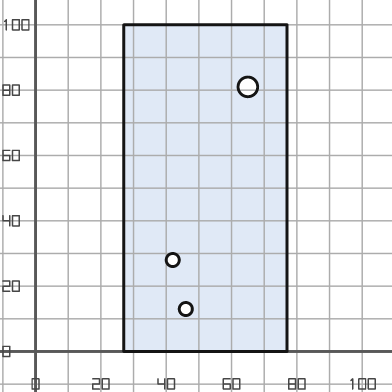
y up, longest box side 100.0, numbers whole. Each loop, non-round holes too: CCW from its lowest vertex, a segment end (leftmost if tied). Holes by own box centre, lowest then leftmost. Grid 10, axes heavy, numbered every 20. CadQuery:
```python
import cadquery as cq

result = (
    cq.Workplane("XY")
    .moveTo(27.0, 0.0)
    .lineTo(77.0, 0.0)
    .lineTo(77.0, 100.0)
    .lineTo(27.0, 100.0)
    .close()
    .moveTo(46.0, 13.0)
    .circle(2.0)
    .moveTo(42.0, 28.0)
    .circle(2.0)
    .moveTo(65.0, 81.0)
    .circle(3.0)
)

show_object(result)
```